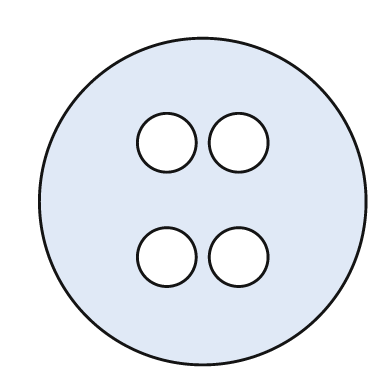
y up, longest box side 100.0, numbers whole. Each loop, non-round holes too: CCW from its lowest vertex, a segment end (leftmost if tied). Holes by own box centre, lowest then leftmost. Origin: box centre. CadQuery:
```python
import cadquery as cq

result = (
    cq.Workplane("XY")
    .moveTo(0.0, 0.0)
    .circle(50.0)
    .moveTo(-11.0, -17.0)
    .circle(9.0)
    .moveTo(11.0, -17.0)
    .circle(9.0)
    .moveTo(-11.0, 18.0)
    .circle(9.0)
    .moveTo(11.0, 18.0)
    .circle(9.0)
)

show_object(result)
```